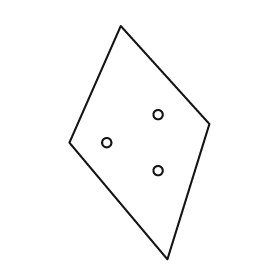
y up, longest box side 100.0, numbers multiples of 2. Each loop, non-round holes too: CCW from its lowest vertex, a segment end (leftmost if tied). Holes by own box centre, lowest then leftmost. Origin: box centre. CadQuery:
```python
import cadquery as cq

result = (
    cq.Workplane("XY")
    .moveTo(12.0, -50.0)
    .lineTo(30.0, 8.0)
    .lineTo(-8.0, 50.0)
    .lineTo(-30.0, 0.0)
    .close()
    .moveTo(8.0, -12.0)
    .circle(2.0)
    .moveTo(-14.0, 0.0)
    .circle(2.0)
    .moveTo(8.0, 12.0)
    .circle(2.0)
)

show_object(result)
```